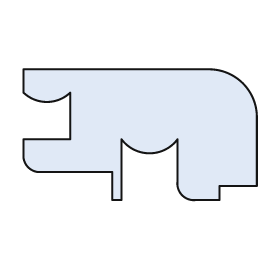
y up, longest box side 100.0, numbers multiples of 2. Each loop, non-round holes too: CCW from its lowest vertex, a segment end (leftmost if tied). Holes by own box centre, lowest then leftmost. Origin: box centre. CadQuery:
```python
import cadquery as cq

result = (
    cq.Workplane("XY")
    .moveTo(-12.0, -28.0)
    .lineTo(-8.0, -28.0)
    .lineTo(-8.0, -2.0)
    .threePointArc((4.0, -8.0), (16.0, -2.0))
    .lineTo(16.0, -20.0)
    .threePointArc((18.0, -26.0), (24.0, -28.0))
    .lineTo(34.0, -28.0)
    .lineTo(34.0, -22.0)
    .lineTo(50.0, -22.0)
    .lineTo(50.0, 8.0)
    .threePointArc((44.0, 22.0), (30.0, 28.0))
    .lineTo(-50.0, 28.0)
    .lineTo(-50.0, 18.0)
    .threePointArc((-40.0, 14.0), (-30.0, 18.0))
    .lineTo(-30.0, -2.0)
    .lineTo(-50.0, -2.0)
    .lineTo(-50.0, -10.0)
    .threePointArc((-48.0, -14.0), (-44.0, -16.0))
    .lineTo(-12.0, -16.0)
    .close()
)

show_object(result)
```